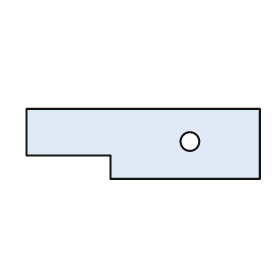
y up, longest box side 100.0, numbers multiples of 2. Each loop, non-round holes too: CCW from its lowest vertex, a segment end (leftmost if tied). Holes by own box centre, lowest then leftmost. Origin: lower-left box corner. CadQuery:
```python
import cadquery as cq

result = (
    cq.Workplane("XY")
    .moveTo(36.0, 0.0)
    .lineTo(100.0, 0.0)
    .lineTo(100.0, 30.0)
    .lineTo(0.0, 30.0)
    .lineTo(0.0, 10.0)
    .lineTo(36.0, 10.0)
    .close()
    .moveTo(70.0, 16.0)
    .circle(4.0)
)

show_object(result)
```